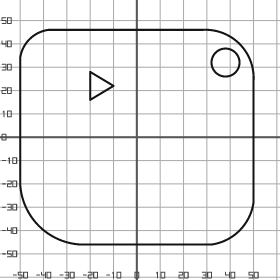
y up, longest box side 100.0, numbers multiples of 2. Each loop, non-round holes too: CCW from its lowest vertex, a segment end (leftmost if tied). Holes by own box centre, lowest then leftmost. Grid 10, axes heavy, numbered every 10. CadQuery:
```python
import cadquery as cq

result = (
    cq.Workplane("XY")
    .moveTo(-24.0, -46.0)
    .lineTo(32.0, -46.0)
    .threePointArc((44.0, -40.0), (50.0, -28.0))
    .lineTo(50.0, 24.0)
    .threePointArc((44.0, 40.0), (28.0, 46.0))
    .lineTo(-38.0, 46.0)
    .threePointArc((-46.0, 42.0), (-50.0, 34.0))
    .lineTo(-50.0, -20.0)
    .threePointArc((-42.0, -38.0), (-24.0, -46.0))
    .close()
    .moveTo(-20.0, 16.0)
    .lineTo(-10.0, 22.0)
    .lineTo(-20.0, 28.0)
    .close()
    .moveTo(38.0, 32.0)
    .circle(6.0)
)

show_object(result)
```